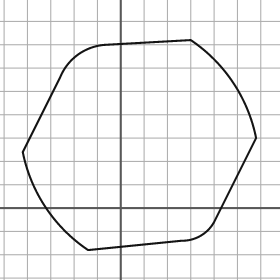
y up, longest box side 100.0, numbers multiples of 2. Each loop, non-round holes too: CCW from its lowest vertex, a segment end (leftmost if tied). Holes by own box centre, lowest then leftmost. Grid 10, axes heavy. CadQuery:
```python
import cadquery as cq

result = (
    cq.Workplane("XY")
    .moveTo(-14.0, -18.0)
    .lineTo(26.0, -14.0)
    .threePointArc((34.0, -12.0), (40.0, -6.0))
    .lineTo(58.0, 30.0)
    .threePointArc((48.0, 54.0), (30.0, 72.0))
    .lineTo(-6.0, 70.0)
    .threePointArc((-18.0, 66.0), (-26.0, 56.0))
    .lineTo(-42.0, 24.0)
    .threePointArc((-32.0, 0.0), (-14.0, -18.0))
    .close()
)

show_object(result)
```